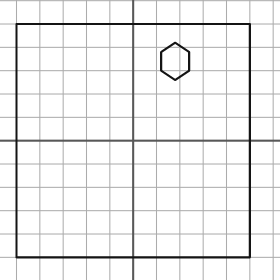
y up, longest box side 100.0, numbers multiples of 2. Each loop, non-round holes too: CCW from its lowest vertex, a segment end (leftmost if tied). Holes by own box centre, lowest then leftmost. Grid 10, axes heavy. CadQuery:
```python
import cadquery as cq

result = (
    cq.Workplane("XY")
    .moveTo(-50.0, -50.0)
    .lineTo(50.0, -50.0)
    .lineTo(50.0, 50.0)
    .lineTo(-50.0, 50.0)
    .close()
    .moveTo(18.0, 26.0)
    .lineTo(24.0, 30.0)
    .lineTo(24.0, 38.0)
    .lineTo(18.0, 42.0)
    .lineTo(12.0, 38.0)
    .lineTo(12.0, 30.0)
    .close()
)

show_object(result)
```